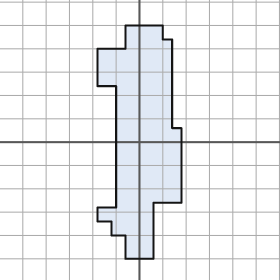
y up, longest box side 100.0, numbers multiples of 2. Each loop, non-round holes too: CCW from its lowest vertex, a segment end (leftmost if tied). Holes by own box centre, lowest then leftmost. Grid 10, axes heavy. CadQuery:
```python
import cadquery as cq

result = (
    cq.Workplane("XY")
    .moveTo(-6.0, -50.0)
    .lineTo(6.0, -50.0)
    .lineTo(6.0, -26.0)
    .lineTo(18.0, -26.0)
    .lineTo(18.0, 6.0)
    .lineTo(14.0, 6.0)
    .lineTo(14.0, 44.0)
    .lineTo(10.0, 44.0)
    .lineTo(10.0, 50.0)
    .lineTo(-6.0, 50.0)
    .lineTo(-6.0, 40.0)
    .lineTo(-18.0, 40.0)
    .lineTo(-18.0, 24.0)
    .lineTo(-10.0, 24.0)
    .lineTo(-10.0, -28.0)
    .lineTo(-18.0, -28.0)
    .lineTo(-18.0, -34.0)
    .lineTo(-12.0, -34.0)
    .lineTo(-12.0, -40.0)
    .lineTo(-6.0, -40.0)
    .close()
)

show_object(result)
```